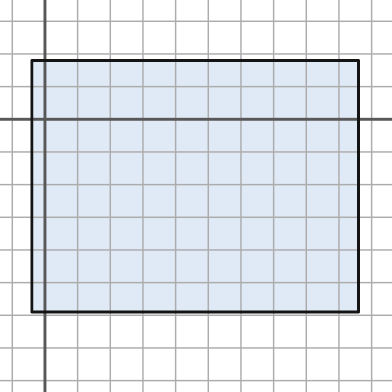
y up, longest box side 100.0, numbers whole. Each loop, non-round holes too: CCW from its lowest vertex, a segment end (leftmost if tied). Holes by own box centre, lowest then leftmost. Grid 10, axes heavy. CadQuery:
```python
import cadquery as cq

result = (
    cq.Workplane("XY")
    .moveTo(-4.0, -59.0)
    .lineTo(96.0, -59.0)
    .lineTo(96.0, 18.0)
    .lineTo(-4.0, 18.0)
    .close()
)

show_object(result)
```